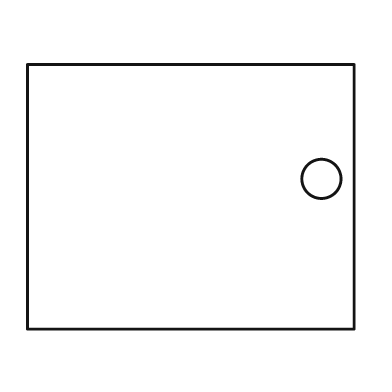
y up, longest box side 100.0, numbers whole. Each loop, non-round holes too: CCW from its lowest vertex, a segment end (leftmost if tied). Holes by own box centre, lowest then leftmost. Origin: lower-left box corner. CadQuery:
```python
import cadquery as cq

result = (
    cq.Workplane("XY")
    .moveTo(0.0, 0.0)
    .lineTo(100.0, 0.0)
    .lineTo(100.0, 81.0)
    .lineTo(0.0, 81.0)
    .close()
    .moveTo(90.0, 46.0)
    .circle(6.0)
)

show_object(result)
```